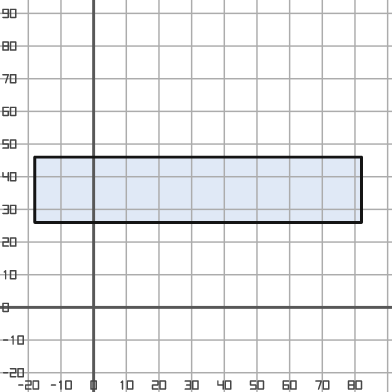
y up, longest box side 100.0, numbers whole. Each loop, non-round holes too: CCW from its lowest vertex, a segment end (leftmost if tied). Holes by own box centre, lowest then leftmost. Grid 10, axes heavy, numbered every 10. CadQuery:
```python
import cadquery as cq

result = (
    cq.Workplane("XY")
    .moveTo(-18.0, 26.0)
    .lineTo(82.0, 26.0)
    .lineTo(82.0, 46.0)
    .lineTo(-18.0, 46.0)
    .close()
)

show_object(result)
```